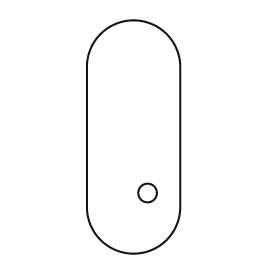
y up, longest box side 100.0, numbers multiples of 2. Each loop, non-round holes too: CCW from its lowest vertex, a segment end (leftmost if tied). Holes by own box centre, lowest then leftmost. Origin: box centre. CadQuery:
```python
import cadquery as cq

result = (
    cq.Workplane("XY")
    .moveTo(-20.0, -30.0)
    .threePointArc((0.0, -50.0), (20.0, -30.0))
    .lineTo(20.0, 30.0)
    .threePointArc((0.0, 50.0), (-20.0, 30.0))
    .close()
    .moveTo(6.0, -24.0)
    .circle(4.0)
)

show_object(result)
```